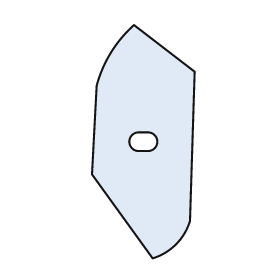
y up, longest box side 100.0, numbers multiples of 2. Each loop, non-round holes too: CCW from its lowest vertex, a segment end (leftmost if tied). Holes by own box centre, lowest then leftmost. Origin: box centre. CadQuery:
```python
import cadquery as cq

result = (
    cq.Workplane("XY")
    .moveTo(4.0, -50.0)
    .threePointArc((14.0, -44.0), (20.0, -34.0))
    .lineTo(22.0, 30.0)
    .lineTo(-4.0, 50.0)
    .threePointArc((-14.0, 38.0), (-20.0, 24.0))
    .lineTo(-22.0, -14.0)
    .close()
    .moveTo(-2.0, -4.0)
    .lineTo(2.0, -4.0)
    .threePointArc((6.0, 0.0), (2.0, 4.0))
    .lineTo(-2.0, 4.0)
    .threePointArc((-6.0, 0.0), (-2.0, -4.0))
    .close()
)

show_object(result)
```